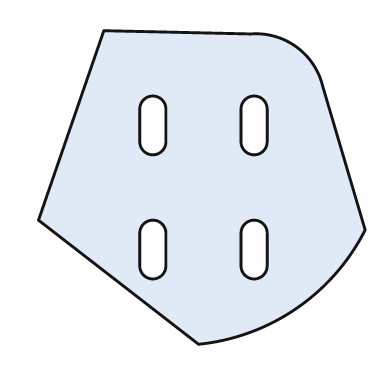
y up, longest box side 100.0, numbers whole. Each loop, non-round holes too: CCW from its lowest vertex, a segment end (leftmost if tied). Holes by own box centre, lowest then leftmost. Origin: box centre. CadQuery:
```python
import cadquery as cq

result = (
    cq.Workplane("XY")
    .moveTo(-1.0, -48.0)
    .threePointArc((29.0, -37.0), (50.0, -13.0))
    .lineTo(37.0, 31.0)
    .threePointArc((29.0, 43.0), (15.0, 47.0))
    .lineTo(-30.0, 48.0)
    .lineTo(-50.0, -10.0)
    .close()
    .moveTo(-19.0, -24.0)
    .threePointArc((-15.0, -28.0), (-11.0, -24.0))
    .lineTo(-11.0, -14.0)
    .threePointArc((-15.0, -10.0), (-19.0, -14.0))
    .close()
    .moveTo(12.0, -24.0)
    .threePointArc((16.0, -28.0), (20.0, -24.0))
    .lineTo(20.0, -14.0)
    .threePointArc((16.0, -10.0), (12.0, -14.0))
    .close()
    .moveTo(-19.0, 14.0)
    .threePointArc((-15.0, 10.0), (-11.0, 14.0))
    .lineTo(-11.0, 24.0)
    .threePointArc((-15.0, 28.0), (-19.0, 24.0))
    .close()
    .moveTo(12.0, 14.0)
    .threePointArc((16.0, 10.0), (20.0, 14.0))
    .lineTo(20.0, 24.0)
    .threePointArc((16.0, 28.0), (12.0, 24.0))
    .close()
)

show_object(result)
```